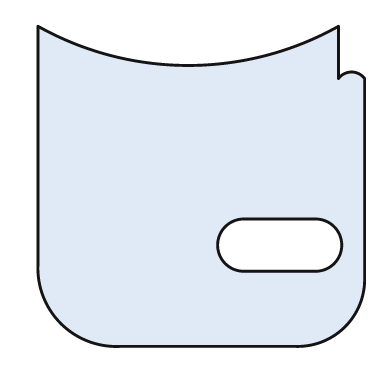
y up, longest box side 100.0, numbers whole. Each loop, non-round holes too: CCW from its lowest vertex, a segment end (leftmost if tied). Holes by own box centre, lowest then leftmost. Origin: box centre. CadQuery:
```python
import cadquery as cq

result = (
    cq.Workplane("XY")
    .moveTo(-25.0, -49.0)
    .lineTo(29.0, -49.0)
    .threePointArc((44.0, -43.0), (50.0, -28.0))
    .lineTo(50.0, 33.0)
    .threePointArc((46.0, 35.0), (42.0, 33.0))
    .lineTo(42.0, 49.0)
    .threePointArc((-4.0, 37.0), (-50.0, 49.0))
    .lineTo(-50.0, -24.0)
    .threePointArc((-43.0, -42.0), (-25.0, -49.0))
    .close()
    .moveTo(13.0, -26.0)
    .lineTo(35.0, -26.0)
    .threePointArc((43.0, -18.0), (35.0, -10.0))
    .lineTo(13.0, -10.0)
    .threePointArc((5.0, -18.0), (13.0, -26.0))
    .close()
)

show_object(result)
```